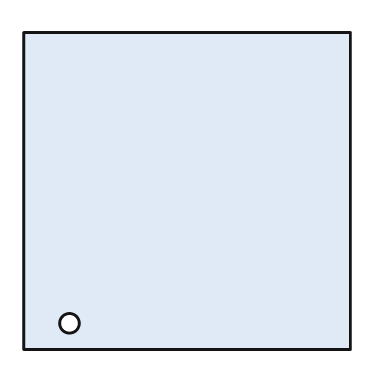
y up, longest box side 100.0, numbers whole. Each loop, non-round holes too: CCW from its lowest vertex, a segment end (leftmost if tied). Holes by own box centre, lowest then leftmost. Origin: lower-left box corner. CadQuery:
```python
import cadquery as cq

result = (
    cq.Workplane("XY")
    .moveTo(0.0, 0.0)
    .lineTo(100.0, 0.0)
    .lineTo(100.0, 97.0)
    .lineTo(0.0, 97.0)
    .close()
    .moveTo(14.0, 8.0)
    .circle(3.0)
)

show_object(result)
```